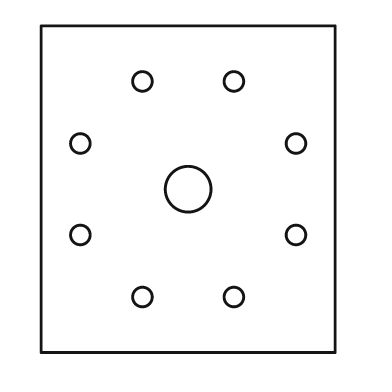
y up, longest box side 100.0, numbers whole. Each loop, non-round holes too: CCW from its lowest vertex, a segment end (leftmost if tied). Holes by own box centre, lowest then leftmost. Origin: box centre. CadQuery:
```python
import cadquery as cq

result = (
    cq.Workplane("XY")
    .moveTo(-45.0, -50.0)
    .lineTo(45.0, -50.0)
    .lineTo(45.0, 50.0)
    .lineTo(-45.0, 50.0)
    .close()
    .moveTo(-14.0, -33.0)
    .circle(3.0)
    .moveTo(14.0, -33.0)
    .circle(3.0)
    .moveTo(-33.0, -14.0)
    .circle(3.0)
    .moveTo(33.0, -14.0)
    .circle(3.0)
    .moveTo(0.0, 0.0)
    .circle(7.0)
    .moveTo(-33.0, 14.0)
    .circle(3.0)
    .moveTo(33.0, 14.0)
    .circle(3.0)
    .moveTo(-14.0, 33.0)
    .circle(3.0)
    .moveTo(14.0, 33.0)
    .circle(3.0)
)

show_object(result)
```